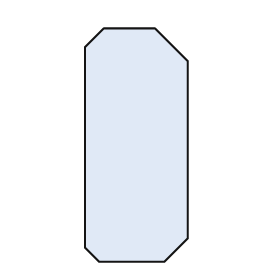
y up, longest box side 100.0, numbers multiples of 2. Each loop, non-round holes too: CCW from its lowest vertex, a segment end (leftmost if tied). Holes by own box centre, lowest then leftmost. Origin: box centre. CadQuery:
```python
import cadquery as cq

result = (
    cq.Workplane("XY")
    .moveTo(-16.0, -50.0)
    .lineTo(12.0, -50.0)
    .lineTo(22.0, -40.0)
    .lineTo(22.0, 36.0)
    .lineTo(8.0, 50.0)
    .lineTo(-14.0, 50.0)
    .lineTo(-22.0, 42.0)
    .lineTo(-22.0, -44.0)
    .close()
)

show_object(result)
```